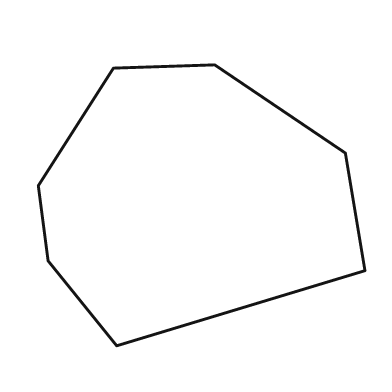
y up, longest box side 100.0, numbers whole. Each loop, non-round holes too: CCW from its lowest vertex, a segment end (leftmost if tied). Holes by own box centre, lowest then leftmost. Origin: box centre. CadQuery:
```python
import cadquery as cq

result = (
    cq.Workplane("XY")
    .moveTo(-26.0, -43.0)
    .lineTo(50.0, -20.0)
    .lineTo(44.0, 16.0)
    .lineTo(4.0, 43.0)
    .lineTo(-27.0, 42.0)
    .lineTo(-50.0, 6.0)
    .lineTo(-47.0, -17.0)
    .close()
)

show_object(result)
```